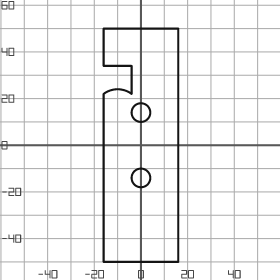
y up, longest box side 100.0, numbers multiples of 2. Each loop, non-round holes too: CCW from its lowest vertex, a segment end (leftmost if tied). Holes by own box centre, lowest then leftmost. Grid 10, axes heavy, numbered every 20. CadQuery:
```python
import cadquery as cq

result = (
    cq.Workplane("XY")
    .moveTo(-16.0, -50.0)
    .lineTo(16.0, -50.0)
    .lineTo(16.0, 50.0)
    .lineTo(-16.0, 50.0)
    .lineTo(-16.0, 34.0)
    .lineTo(-4.0, 34.0)
    .lineTo(-4.0, 22.0)
    .threePointArc((-10.0, 24.0), (-16.0, 22.0))
    .close()
    .moveTo(0.0, -14.0)
    .circle(4.0)
    .moveTo(0.0, 14.0)
    .circle(4.0)
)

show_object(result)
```